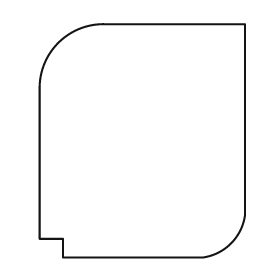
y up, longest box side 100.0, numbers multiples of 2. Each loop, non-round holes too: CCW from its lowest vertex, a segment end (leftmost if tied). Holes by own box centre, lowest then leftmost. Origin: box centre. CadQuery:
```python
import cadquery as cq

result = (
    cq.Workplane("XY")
    .moveTo(-34.0, -50.0)
    .lineTo(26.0, -50.0)
    .threePointArc((38.0, -44.0), (44.0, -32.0))
    .lineTo(44.0, 50.0)
    .lineTo(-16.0, 50.0)
    .threePointArc((-36.0, 42.0), (-44.0, 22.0))
    .lineTo(-44.0, -42.0)
    .lineTo(-34.0, -42.0)
    .close()
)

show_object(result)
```